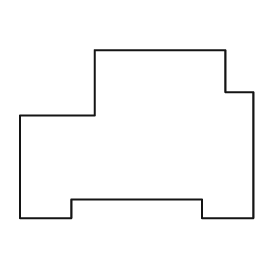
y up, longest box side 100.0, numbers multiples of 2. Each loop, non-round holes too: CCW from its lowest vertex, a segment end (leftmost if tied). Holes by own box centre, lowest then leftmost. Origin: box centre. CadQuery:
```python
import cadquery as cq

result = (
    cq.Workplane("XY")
    .moveTo(-50.0, -36.0)
    .lineTo(-28.0, -36.0)
    .lineTo(-28.0, -28.0)
    .lineTo(28.0, -28.0)
    .lineTo(28.0, -36.0)
    .lineTo(50.0, -36.0)
    .lineTo(50.0, 18.0)
    .lineTo(38.0, 18.0)
    .lineTo(38.0, 36.0)
    .lineTo(-18.0, 36.0)
    .lineTo(-18.0, 8.0)
    .lineTo(-50.0, 8.0)
    .close()
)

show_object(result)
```